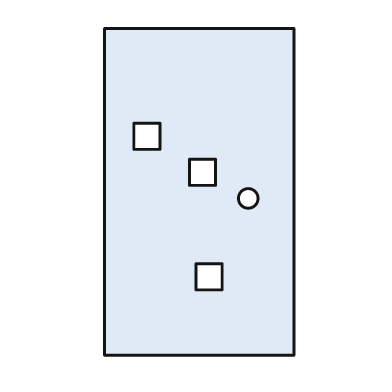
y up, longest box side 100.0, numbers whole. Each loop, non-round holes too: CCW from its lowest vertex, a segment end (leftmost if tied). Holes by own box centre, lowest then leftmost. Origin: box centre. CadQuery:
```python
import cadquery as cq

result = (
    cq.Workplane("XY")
    .moveTo(-29.0, -50.0)
    .lineTo(29.0, -50.0)
    .lineTo(29.0, 50.0)
    .lineTo(-29.0, 50.0)
    .close()
    .moveTo(-1.0, -30.0)
    .lineTo(7.0, -30.0)
    .lineTo(7.0, -22.0)
    .lineTo(-1.0, -22.0)
    .close()
    .moveTo(15.0, -2.0)
    .circle(3.0)
    .moveTo(-3.0, 2.0)
    .lineTo(5.0, 2.0)
    .lineTo(5.0, 10.0)
    .lineTo(-3.0, 10.0)
    .close()
    .moveTo(-20.0, 13.0)
    .lineTo(-12.0, 13.0)
    .lineTo(-12.0, 21.0)
    .lineTo(-20.0, 21.0)
    .close()
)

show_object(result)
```